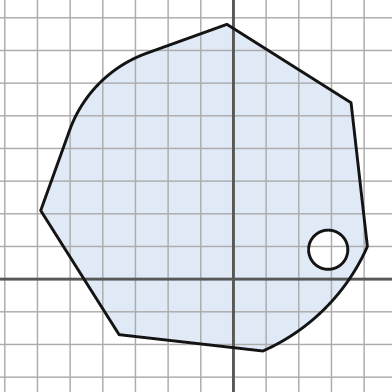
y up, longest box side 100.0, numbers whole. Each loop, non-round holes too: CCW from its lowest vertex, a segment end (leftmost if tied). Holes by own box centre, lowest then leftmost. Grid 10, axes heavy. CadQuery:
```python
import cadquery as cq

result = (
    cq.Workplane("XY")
    .moveTo(9.0, -22.0)
    .threePointArc((28.0, -9.0), (41.0, 10.0))
    .lineTo(36.0, 54.0)
    .lineTo(-2.0, 78.0)
    .lineTo(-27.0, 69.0)
    .threePointArc((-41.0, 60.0), (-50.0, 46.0))
    .lineTo(-59.0, 21.0)
    .lineTo(-35.0, -17.0)
    .close()
    .moveTo(29.0, 9.0)
    .circle(6.0)
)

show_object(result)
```